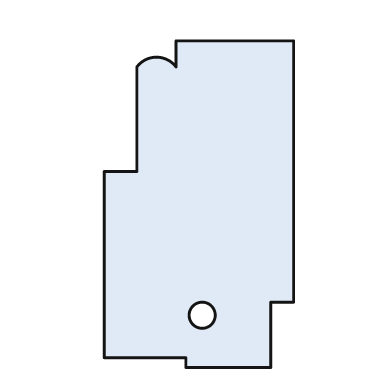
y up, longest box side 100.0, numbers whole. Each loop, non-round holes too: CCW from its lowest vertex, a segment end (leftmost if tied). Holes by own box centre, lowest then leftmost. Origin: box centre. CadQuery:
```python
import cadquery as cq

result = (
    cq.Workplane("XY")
    .moveTo(-4.0, -50.0)
    .lineTo(22.0, -50.0)
    .lineTo(22.0, -30.0)
    .lineTo(29.0, -30.0)
    .lineTo(29.0, 50.0)
    .lineTo(-7.0, 50.0)
    .lineTo(-7.0, 42.0)
    .threePointArc((-13.0, 45.0), (-19.0, 42.0))
    .lineTo(-19.0, 10.0)
    .lineTo(-29.0, 10.0)
    .lineTo(-29.0, -47.0)
    .lineTo(-4.0, -47.0)
    .close()
    .moveTo(1.0, -34.0)
    .circle(4.0)
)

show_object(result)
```